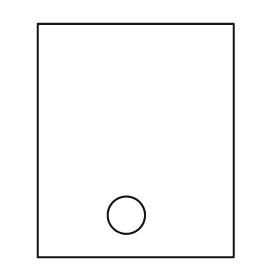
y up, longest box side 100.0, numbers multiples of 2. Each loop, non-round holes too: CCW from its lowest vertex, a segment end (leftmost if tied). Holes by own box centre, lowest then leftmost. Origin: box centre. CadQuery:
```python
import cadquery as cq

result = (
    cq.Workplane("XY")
    .moveTo(-42.0, -50.0)
    .lineTo(42.0, -50.0)
    .lineTo(42.0, 50.0)
    .lineTo(-42.0, 50.0)
    .close()
    .moveTo(-4.0, -32.0)
    .circle(8.0)
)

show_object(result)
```